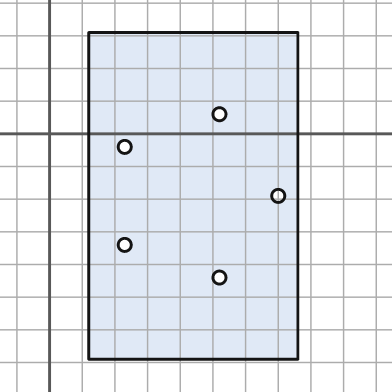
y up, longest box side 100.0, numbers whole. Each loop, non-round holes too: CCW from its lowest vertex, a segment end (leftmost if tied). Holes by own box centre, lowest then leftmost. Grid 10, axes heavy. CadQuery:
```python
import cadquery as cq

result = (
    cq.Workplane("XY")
    .moveTo(12.0, -69.0)
    .lineTo(76.0, -69.0)
    .lineTo(76.0, 31.0)
    .lineTo(12.0, 31.0)
    .close()
    .moveTo(52.0, -44.0)
    .circle(2.0)
    .moveTo(23.0, -34.0)
    .circle(2.0)
    .moveTo(70.0, -19.0)
    .circle(2.0)
    .moveTo(23.0, -4.0)
    .circle(2.0)
    .moveTo(52.0, 6.0)
    .circle(2.0)
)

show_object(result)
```